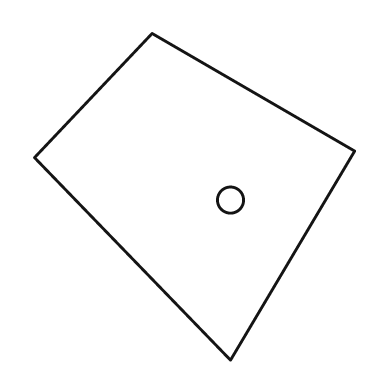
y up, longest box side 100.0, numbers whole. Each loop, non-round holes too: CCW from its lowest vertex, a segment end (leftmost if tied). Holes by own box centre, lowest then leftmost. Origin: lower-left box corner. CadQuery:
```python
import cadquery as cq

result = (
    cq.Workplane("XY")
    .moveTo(60.0, 0.0)
    .lineTo(98.0, 64.0)
    .lineTo(36.0, 100.0)
    .lineTo(0.0, 62.0)
    .close()
    .moveTo(60.0, 49.0)
    .circle(4.0)
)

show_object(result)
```